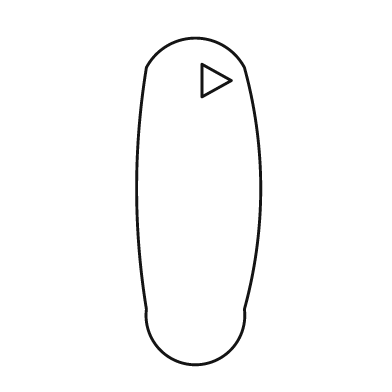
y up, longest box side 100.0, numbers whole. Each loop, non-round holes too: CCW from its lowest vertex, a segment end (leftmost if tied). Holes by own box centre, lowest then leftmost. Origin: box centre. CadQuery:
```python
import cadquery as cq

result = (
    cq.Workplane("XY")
    .moveTo(-16.0, -33.0)
    .threePointArc((-1.0, -50.0), (14.0, -33.0))
    .threePointArc((19.0, 4.0), (14.0, 41.0))
    .threePointArc((-1.0, 50.0), (-16.0, 41.0))
    .threePointArc((-19.0, 4.0), (-16.0, -33.0))
    .close()
    .moveTo(1.0, 32.0)
    .lineTo(10.0, 37.0)
    .lineTo(1.0, 42.0)
    .close()
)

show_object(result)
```